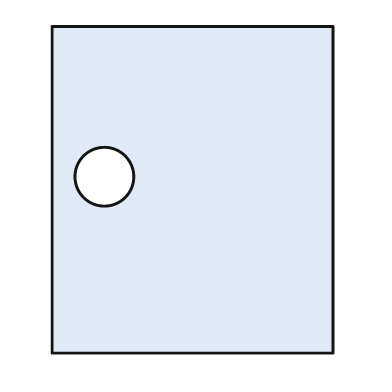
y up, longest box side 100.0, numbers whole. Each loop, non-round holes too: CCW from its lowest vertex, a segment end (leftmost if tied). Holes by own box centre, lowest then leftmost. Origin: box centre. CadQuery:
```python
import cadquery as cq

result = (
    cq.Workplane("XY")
    .moveTo(-43.0, -50.0)
    .lineTo(43.0, -50.0)
    .lineTo(43.0, 50.0)
    .lineTo(-43.0, 50.0)
    .close()
    .moveTo(-27.0, 4.0)
    .circle(9.0)
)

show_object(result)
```